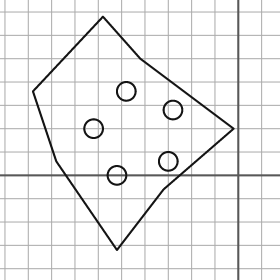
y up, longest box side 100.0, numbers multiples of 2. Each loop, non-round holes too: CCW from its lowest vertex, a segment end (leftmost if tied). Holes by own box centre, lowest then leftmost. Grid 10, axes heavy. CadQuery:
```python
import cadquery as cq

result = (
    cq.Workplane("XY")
    .moveTo(-52.0, -32.0)
    .lineTo(-32.0, -6.0)
    .lineTo(-2.0, 20.0)
    .lineTo(-42.0, 50.0)
    .lineTo(-58.0, 68.0)
    .lineTo(-88.0, 36.0)
    .lineTo(-78.0, 6.0)
    .close()
    .moveTo(-52.0, 0.0)
    .circle(4.0)
    .moveTo(-30.0, 6.0)
    .circle(4.0)
    .moveTo(-62.0, 20.0)
    .circle(4.0)
    .moveTo(-28.0, 28.0)
    .circle(4.0)
    .moveTo(-48.0, 36.0)
    .circle(4.0)
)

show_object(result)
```